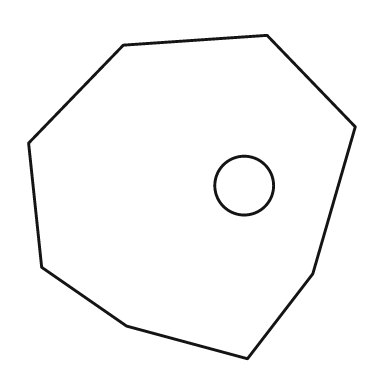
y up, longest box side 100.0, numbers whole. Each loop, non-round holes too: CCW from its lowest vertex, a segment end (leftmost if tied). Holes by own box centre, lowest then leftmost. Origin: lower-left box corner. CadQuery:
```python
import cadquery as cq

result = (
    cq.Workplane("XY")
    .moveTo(67.0, 0.0)
    .lineTo(87.0, 26.0)
    .lineTo(100.0, 71.0)
    .lineTo(73.0, 99.0)
    .lineTo(29.0, 96.0)
    .lineTo(0.0, 66.0)
    .lineTo(4.0, 28.0)
    .lineTo(30.0, 10.0)
    .close()
    .moveTo(66.0, 53.0)
    .circle(9.0)
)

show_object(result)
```